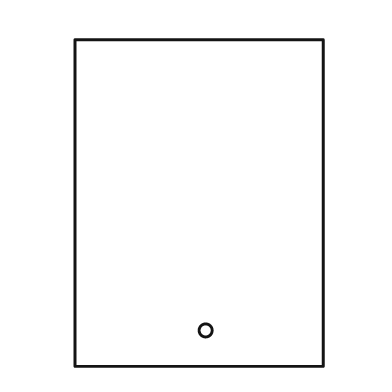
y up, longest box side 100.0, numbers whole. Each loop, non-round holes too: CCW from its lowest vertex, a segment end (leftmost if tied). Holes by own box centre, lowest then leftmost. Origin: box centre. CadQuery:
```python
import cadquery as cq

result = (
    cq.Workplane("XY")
    .moveTo(-38.0, -50.0)
    .lineTo(38.0, -50.0)
    .lineTo(38.0, 50.0)
    .lineTo(-38.0, 50.0)
    .close()
    .moveTo(2.0, -39.0)
    .circle(2.0)
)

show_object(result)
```